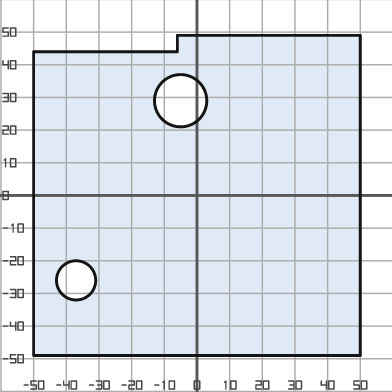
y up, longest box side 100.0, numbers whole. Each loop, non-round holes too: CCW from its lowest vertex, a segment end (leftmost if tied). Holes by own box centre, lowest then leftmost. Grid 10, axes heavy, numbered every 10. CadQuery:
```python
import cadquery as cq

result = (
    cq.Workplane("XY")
    .moveTo(-50.0, -49.0)
    .lineTo(50.0, -49.0)
    .lineTo(50.0, 49.0)
    .lineTo(-6.0, 49.0)
    .lineTo(-6.0, 44.0)
    .lineTo(-50.0, 44.0)
    .close()
    .moveTo(-37.0, -26.0)
    .circle(6.0)
    .moveTo(-5.0, 29.0)
    .circle(8.0)
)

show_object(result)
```